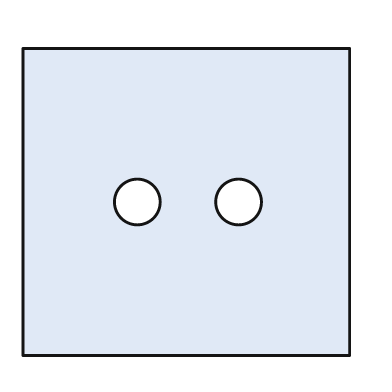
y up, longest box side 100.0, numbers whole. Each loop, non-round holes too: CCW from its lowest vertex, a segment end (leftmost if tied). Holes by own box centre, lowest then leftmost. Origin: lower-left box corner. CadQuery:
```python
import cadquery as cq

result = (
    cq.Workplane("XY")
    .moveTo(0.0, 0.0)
    .lineTo(100.0, 0.0)
    .lineTo(100.0, 94.0)
    .lineTo(0.0, 94.0)
    .close()
    .moveTo(35.0, 47.0)
    .circle(7.0)
    .moveTo(66.0, 47.0)
    .circle(7.0)
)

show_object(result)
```